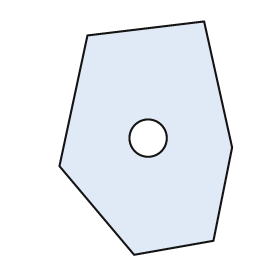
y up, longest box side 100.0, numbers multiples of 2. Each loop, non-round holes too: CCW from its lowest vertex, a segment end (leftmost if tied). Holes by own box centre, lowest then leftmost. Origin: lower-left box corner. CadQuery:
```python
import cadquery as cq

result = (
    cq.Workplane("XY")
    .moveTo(32.0, 0.0)
    .lineTo(66.0, 6.0)
    .lineTo(74.0, 46.0)
    .lineTo(62.0, 100.0)
    .lineTo(12.0, 94.0)
    .lineTo(0.0, 38.0)
    .close()
    .moveTo(38.0, 50.0)
    .circle(8.0)
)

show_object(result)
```